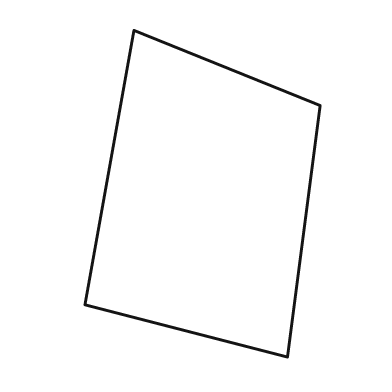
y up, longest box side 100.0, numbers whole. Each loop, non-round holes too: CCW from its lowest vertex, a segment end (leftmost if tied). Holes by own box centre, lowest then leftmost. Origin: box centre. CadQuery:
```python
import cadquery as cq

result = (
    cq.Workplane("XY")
    .moveTo(26.0, -50.0)
    .lineTo(36.0, 27.0)
    .lineTo(-21.0, 50.0)
    .lineTo(-36.0, -34.0)
    .close()
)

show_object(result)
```